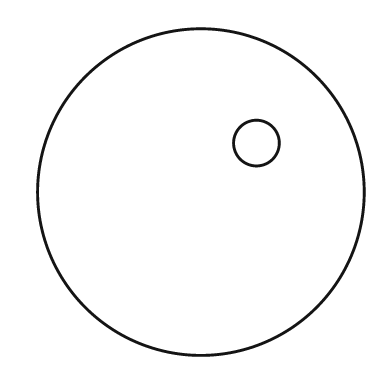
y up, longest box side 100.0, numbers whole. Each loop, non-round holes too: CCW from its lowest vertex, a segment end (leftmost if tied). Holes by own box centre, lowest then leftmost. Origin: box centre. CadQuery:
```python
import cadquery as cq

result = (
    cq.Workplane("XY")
    .moveTo(0.0, 0.0)
    .circle(50.0)
    .moveTo(17.0, 15.0)
    .circle(7.0)
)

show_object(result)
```